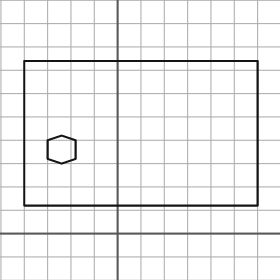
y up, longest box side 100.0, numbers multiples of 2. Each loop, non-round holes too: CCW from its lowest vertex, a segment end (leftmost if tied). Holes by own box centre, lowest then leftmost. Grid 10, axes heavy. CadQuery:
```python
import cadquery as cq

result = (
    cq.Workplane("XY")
    .moveTo(-40.0, 12.0)
    .lineTo(60.0, 12.0)
    .lineTo(60.0, 74.0)
    .lineTo(-40.0, 74.0)
    .close()
    .moveTo(-24.0, 30.0)
    .lineTo(-18.0, 32.0)
    .lineTo(-18.0, 40.0)
    .lineTo(-24.0, 42.0)
    .lineTo(-30.0, 40.0)
    .lineTo(-30.0, 32.0)
    .close()
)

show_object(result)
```